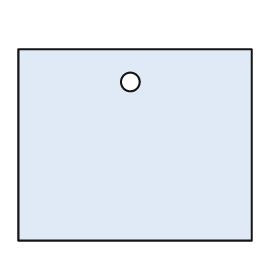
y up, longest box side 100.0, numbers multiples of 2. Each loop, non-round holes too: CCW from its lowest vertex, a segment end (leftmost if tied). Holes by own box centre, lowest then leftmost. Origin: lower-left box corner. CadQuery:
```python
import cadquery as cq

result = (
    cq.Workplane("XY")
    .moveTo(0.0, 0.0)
    .lineTo(100.0, 0.0)
    .lineTo(100.0, 82.0)
    .lineTo(0.0, 82.0)
    .close()
    .moveTo(48.0, 68.0)
    .circle(4.0)
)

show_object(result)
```